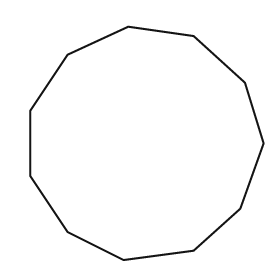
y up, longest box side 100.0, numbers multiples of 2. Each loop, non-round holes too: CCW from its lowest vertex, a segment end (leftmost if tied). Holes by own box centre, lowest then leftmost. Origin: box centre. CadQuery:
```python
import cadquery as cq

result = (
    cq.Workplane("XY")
    .moveTo(-10.0, -50.0)
    .lineTo(20.0, -46.0)
    .lineTo(40.0, -28.0)
    .lineTo(50.0, 0.0)
    .lineTo(42.0, 26.0)
    .lineTo(20.0, 46.0)
    .lineTo(-8.0, 50.0)
    .lineTo(-34.0, 38.0)
    .lineTo(-50.0, 14.0)
    .lineTo(-50.0, -14.0)
    .lineTo(-34.0, -38.0)
    .close()
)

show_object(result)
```